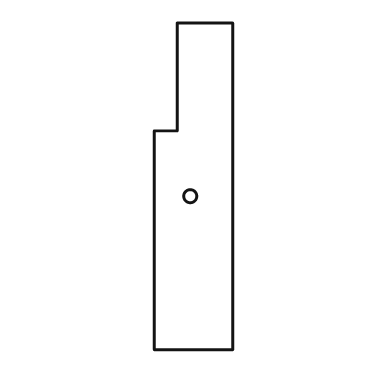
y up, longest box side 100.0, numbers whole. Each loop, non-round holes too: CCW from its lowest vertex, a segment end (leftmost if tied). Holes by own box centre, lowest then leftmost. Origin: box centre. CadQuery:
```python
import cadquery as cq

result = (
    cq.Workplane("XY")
    .moveTo(-12.0, -50.0)
    .lineTo(12.0, -50.0)
    .lineTo(12.0, 50.0)
    .lineTo(-5.0, 50.0)
    .lineTo(-5.0, 17.0)
    .lineTo(-12.0, 17.0)
    .close()
    .moveTo(-1.0, -3.0)
    .circle(2.0)
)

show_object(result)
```